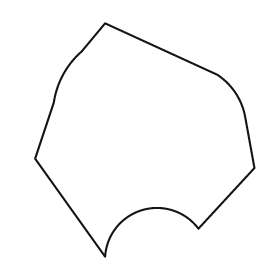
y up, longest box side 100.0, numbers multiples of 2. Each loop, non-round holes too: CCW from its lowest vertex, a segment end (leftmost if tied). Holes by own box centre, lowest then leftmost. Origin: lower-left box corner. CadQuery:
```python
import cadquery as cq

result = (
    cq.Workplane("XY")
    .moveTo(30.0, 0.0)
    .threePointArc((46.0, 20.0), (70.0, 12.0))
    .lineTo(94.0, 38.0)
    .lineTo(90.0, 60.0)
    .threePointArc((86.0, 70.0), (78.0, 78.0))
    .lineTo(30.0, 100.0)
    .lineTo(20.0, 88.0)
    .threePointArc((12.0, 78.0), (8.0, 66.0))
    .lineTo(0.0, 42.0)
    .close()
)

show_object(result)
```